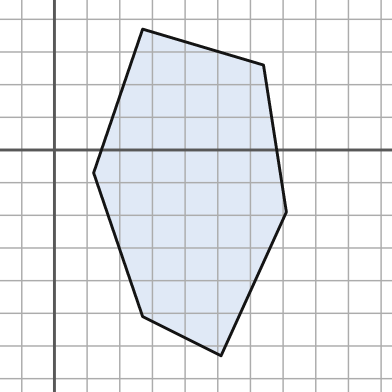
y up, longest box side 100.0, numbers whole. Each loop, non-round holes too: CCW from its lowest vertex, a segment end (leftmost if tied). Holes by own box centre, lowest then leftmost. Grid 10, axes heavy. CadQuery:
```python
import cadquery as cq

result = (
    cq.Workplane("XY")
    .moveTo(51.0, -63.0)
    .lineTo(71.0, -19.0)
    .lineTo(64.0, 26.0)
    .lineTo(27.0, 37.0)
    .lineTo(12.0, -7.0)
    .lineTo(27.0, -51.0)
    .close()
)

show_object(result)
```